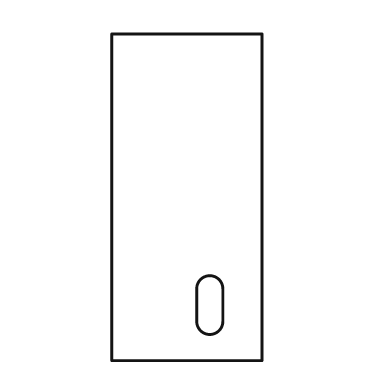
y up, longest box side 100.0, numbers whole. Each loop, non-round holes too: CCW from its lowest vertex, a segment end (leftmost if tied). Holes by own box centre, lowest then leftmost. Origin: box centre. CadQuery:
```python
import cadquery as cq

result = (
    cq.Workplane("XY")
    .moveTo(-23.0, -50.0)
    .lineTo(23.0, -50.0)
    .lineTo(23.0, 50.0)
    .lineTo(-23.0, 50.0)
    .close()
    .moveTo(3.0, -38.0)
    .threePointArc((7.0, -42.0), (11.0, -38.0))
    .lineTo(11.0, -28.0)
    .threePointArc((7.0, -24.0), (3.0, -28.0))
    .close()
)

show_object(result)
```